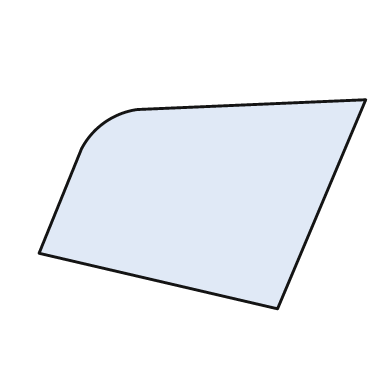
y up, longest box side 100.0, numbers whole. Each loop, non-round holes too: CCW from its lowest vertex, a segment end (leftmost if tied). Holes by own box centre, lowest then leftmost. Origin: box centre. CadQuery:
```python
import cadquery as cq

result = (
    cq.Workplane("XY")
    .moveTo(23.0, -32.0)
    .lineTo(50.0, 32.0)
    .lineTo(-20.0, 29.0)
    .threePointArc((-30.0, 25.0), (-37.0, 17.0))
    .lineTo(-50.0, -15.0)
    .close()
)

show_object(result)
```